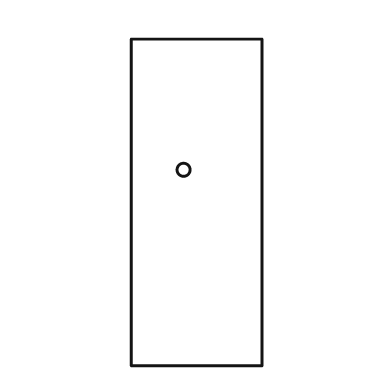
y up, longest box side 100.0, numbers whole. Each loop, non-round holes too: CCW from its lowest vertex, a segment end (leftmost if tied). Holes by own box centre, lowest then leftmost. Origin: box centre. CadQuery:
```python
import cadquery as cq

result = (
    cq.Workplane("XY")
    .moveTo(-20.0, -50.0)
    .lineTo(20.0, -50.0)
    .lineTo(20.0, 50.0)
    .lineTo(-20.0, 50.0)
    .close()
    .moveTo(-4.0, 10.0)
    .circle(2.0)
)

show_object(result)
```